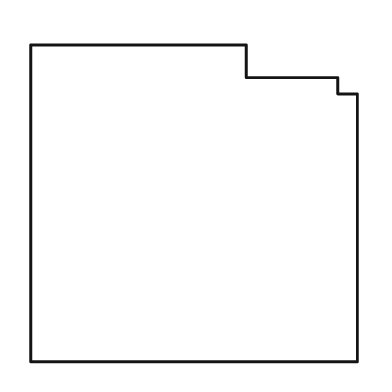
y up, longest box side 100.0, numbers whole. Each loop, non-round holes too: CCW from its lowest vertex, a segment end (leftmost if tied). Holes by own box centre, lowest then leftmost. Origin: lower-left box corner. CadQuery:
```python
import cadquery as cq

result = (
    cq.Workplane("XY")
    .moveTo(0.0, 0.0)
    .lineTo(100.0, 0.0)
    .lineTo(100.0, 82.0)
    .lineTo(94.0, 82.0)
    .lineTo(94.0, 87.0)
    .lineTo(66.0, 87.0)
    .lineTo(66.0, 97.0)
    .lineTo(0.0, 97.0)
    .close()
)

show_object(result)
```